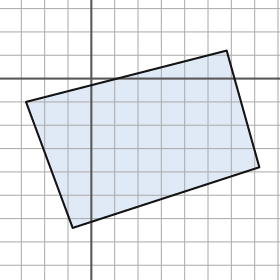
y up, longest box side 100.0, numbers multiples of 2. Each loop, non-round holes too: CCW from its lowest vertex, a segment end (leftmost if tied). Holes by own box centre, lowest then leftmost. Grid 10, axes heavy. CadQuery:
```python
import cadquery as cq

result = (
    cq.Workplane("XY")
    .moveTo(-8.0, -64.0)
    .lineTo(72.0, -38.0)
    .lineTo(58.0, 12.0)
    .lineTo(-28.0, -10.0)
    .close()
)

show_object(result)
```